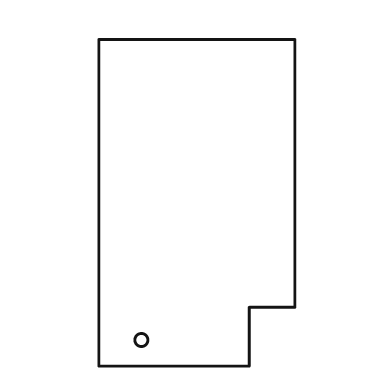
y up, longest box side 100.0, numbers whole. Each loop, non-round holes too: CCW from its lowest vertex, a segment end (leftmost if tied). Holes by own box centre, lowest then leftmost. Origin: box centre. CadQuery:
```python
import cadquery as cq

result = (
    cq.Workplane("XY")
    .moveTo(-30.0, -50.0)
    .lineTo(16.0, -50.0)
    .lineTo(16.0, -32.0)
    .lineTo(30.0, -32.0)
    .lineTo(30.0, 50.0)
    .lineTo(-30.0, 50.0)
    .close()
    .moveTo(-17.0, -42.0)
    .circle(2.0)
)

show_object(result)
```